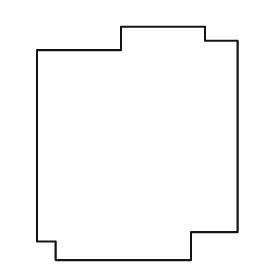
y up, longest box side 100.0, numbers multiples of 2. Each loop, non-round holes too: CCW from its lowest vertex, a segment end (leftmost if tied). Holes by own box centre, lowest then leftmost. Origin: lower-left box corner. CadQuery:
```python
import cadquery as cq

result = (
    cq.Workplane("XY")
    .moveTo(8.0, 0.0)
    .lineTo(66.0, 0.0)
    .lineTo(66.0, 12.0)
    .lineTo(86.0, 12.0)
    .lineTo(86.0, 94.0)
    .lineTo(72.0, 94.0)
    .lineTo(72.0, 100.0)
    .lineTo(36.0, 100.0)
    .lineTo(36.0, 90.0)
    .lineTo(0.0, 90.0)
    .lineTo(0.0, 8.0)
    .lineTo(8.0, 8.0)
    .close()
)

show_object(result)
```